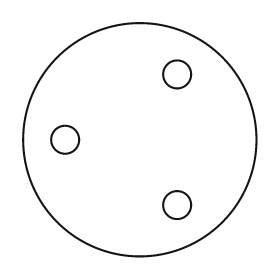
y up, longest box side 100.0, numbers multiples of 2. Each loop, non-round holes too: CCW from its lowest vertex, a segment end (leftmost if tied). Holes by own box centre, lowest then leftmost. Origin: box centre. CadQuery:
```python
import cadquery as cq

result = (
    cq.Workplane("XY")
    .moveTo(0.0, 0.0)
    .circle(50.0)
    .moveTo(16.0, -28.0)
    .circle(6.0)
    .moveTo(-32.0, 0.0)
    .circle(6.0)
    .moveTo(16.0, 28.0)
    .circle(6.0)
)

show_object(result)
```